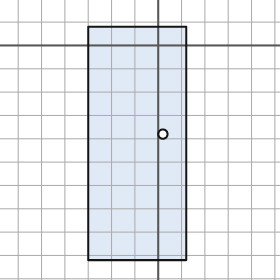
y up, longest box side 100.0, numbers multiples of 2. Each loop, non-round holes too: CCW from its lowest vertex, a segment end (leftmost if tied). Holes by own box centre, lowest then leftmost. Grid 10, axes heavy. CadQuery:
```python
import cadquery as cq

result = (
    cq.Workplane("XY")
    .moveTo(-30.0, -92.0)
    .lineTo(12.0, -92.0)
    .lineTo(12.0, 8.0)
    .lineTo(-30.0, 8.0)
    .close()
    .moveTo(2.0, -38.0)
    .circle(2.0)
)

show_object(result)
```